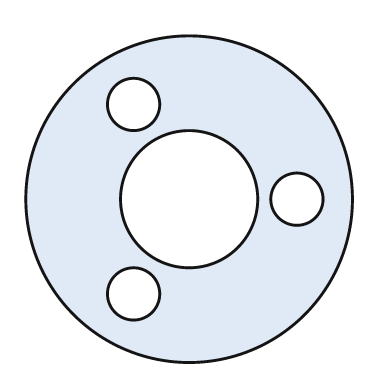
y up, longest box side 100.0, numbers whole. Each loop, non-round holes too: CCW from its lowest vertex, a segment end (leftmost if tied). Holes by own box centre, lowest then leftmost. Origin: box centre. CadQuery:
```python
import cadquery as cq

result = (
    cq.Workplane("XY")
    .moveTo(0.0, 0.0)
    .circle(50.0)
    .moveTo(-17.0, -29.0)
    .circle(8.0)
    .moveTo(0.0, 0.0)
    .circle(21.0)
    .moveTo(33.0, 0.0)
    .circle(8.0)
    .moveTo(-17.0, 29.0)
    .circle(8.0)
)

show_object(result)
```